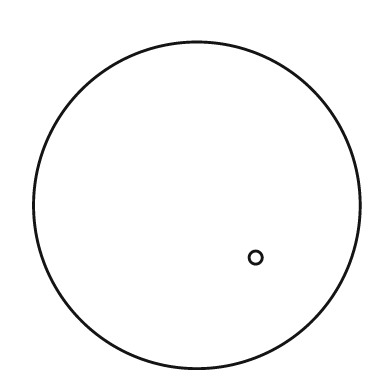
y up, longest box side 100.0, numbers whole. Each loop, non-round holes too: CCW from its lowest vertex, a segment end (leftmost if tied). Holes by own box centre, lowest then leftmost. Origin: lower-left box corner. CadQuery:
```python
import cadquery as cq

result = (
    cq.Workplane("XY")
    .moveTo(50.0, 50.0)
    .circle(50.0)
    .moveTo(68.0, 34.0)
    .circle(2.0)
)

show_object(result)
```